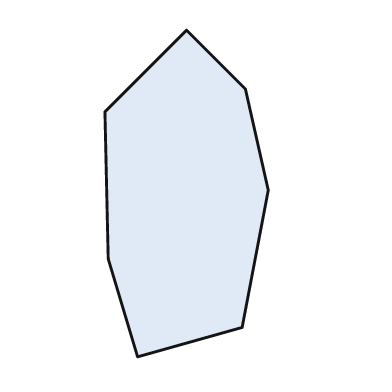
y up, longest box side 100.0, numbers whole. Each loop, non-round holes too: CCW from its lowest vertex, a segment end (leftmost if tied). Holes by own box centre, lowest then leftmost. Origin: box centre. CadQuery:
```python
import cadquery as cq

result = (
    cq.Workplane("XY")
    .moveTo(-15.0, -50.0)
    .lineTo(17.0, -41.0)
    .lineTo(25.0, 1.0)
    .lineTo(18.0, 32.0)
    .lineTo(0.0, 50.0)
    .lineTo(-25.0, 25.0)
    .lineTo(-24.0, -20.0)
    .close()
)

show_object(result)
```